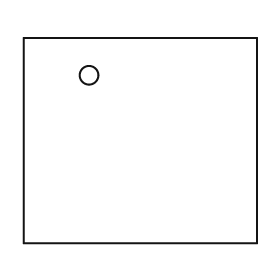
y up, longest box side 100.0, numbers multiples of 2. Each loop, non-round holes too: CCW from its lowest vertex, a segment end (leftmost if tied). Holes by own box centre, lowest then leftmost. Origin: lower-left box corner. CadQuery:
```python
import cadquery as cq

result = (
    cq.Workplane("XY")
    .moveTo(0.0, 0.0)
    .lineTo(100.0, 0.0)
    .lineTo(100.0, 88.0)
    .lineTo(0.0, 88.0)
    .close()
    .moveTo(28.0, 72.0)
    .circle(4.0)
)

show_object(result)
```